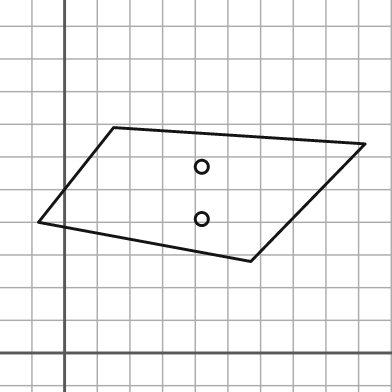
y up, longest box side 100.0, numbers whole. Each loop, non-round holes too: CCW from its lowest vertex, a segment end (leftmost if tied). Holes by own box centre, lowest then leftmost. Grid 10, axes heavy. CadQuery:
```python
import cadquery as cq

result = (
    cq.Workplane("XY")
    .moveTo(57.0, 28.0)
    .lineTo(92.0, 64.0)
    .lineTo(15.0, 69.0)
    .lineTo(-8.0, 40.0)
    .close()
    .moveTo(42.0, 41.0)
    .circle(2.0)
    .moveTo(42.0, 57.0)
    .circle(2.0)
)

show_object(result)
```